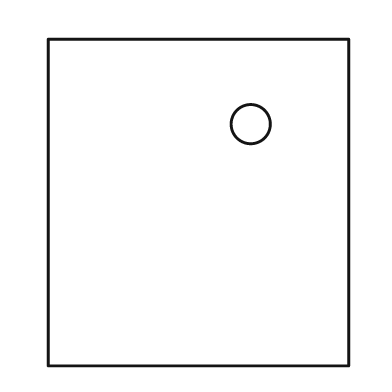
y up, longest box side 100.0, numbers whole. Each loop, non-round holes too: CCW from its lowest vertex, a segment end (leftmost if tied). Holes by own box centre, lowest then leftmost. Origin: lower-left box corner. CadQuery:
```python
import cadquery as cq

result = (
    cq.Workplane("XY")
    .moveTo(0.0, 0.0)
    .lineTo(92.0, 0.0)
    .lineTo(92.0, 100.0)
    .lineTo(0.0, 100.0)
    .close()
    .moveTo(62.0, 74.0)
    .circle(6.0)
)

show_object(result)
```